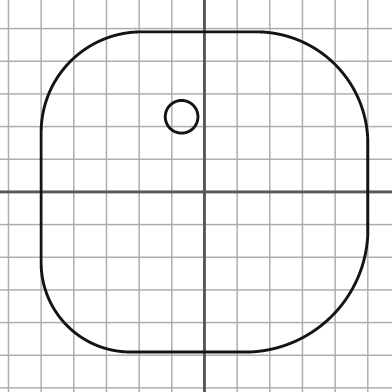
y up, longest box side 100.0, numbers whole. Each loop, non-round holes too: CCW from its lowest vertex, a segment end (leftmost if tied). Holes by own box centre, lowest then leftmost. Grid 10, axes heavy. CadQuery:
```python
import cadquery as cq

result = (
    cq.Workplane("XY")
    .moveTo(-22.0, -49.0)
    .lineTo(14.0, -49.0)
    .threePointArc((39.0, -38.0), (50.0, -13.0))
    .lineTo(50.0, 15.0)
    .threePointArc((40.0, 39.0), (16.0, 49.0))
    .lineTo(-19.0, 49.0)
    .threePointArc((-41.0, 40.0), (-50.0, 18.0))
    .lineTo(-50.0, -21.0)
    .threePointArc((-42.0, -41.0), (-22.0, -49.0))
    .close()
    .moveTo(-7.0, 23.0)
    .circle(5.0)
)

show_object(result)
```